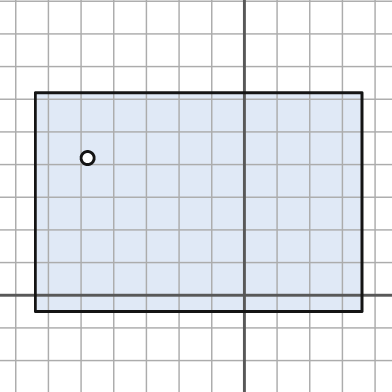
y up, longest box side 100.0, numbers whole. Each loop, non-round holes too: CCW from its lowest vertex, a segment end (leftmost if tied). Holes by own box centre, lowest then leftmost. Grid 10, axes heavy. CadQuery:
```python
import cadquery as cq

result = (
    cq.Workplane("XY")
    .moveTo(-64.0, -5.0)
    .lineTo(36.0, -5.0)
    .lineTo(36.0, 62.0)
    .lineTo(-64.0, 62.0)
    .close()
    .moveTo(-48.0, 42.0)
    .circle(2.0)
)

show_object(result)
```